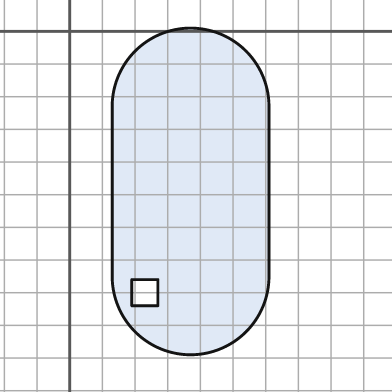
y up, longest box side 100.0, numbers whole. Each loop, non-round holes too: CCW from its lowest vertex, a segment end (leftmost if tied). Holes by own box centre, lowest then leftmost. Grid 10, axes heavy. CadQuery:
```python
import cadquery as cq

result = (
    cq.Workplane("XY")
    .moveTo(13.0, -75.0)
    .threePointArc((37.0, -99.0), (61.0, -75.0))
    .lineTo(61.0, -23.0)
    .threePointArc((37.0, 1.0), (13.0, -23.0))
    .close()
    .moveTo(19.0, -84.0)
    .lineTo(27.0, -84.0)
    .lineTo(27.0, -76.0)
    .lineTo(19.0, -76.0)
    .close()
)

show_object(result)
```